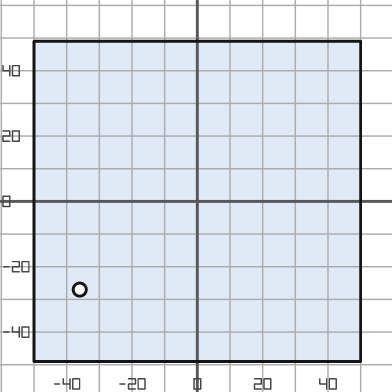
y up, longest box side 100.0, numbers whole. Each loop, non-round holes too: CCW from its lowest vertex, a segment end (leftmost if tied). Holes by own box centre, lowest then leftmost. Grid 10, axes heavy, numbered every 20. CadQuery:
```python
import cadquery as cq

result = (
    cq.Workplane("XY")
    .moveTo(-50.0, -49.0)
    .lineTo(50.0, -49.0)
    .lineTo(50.0, 49.0)
    .lineTo(-50.0, 49.0)
    .close()
    .moveTo(-36.0, -27.0)
    .circle(2.0)
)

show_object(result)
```